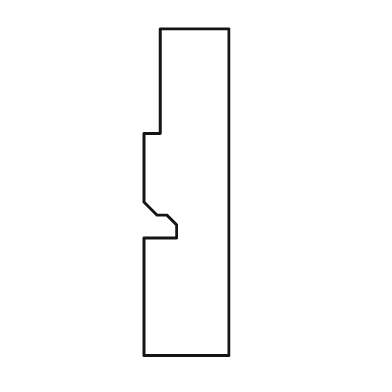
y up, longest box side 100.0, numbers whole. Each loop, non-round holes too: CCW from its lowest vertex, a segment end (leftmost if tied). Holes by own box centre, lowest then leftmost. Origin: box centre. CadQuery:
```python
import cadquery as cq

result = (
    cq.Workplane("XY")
    .moveTo(-13.0, -50.0)
    .lineTo(13.0, -50.0)
    .lineTo(13.0, 50.0)
    .lineTo(-8.0, 50.0)
    .lineTo(-8.0, 18.0)
    .lineTo(-13.0, 18.0)
    .lineTo(-13.0, -3.0)
    .lineTo(-9.0, -7.0)
    .lineTo(-6.0, -7.0)
    .lineTo(-3.0, -10.0)
    .lineTo(-3.0, -14.0)
    .lineTo(-13.0, -14.0)
    .close()
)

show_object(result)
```